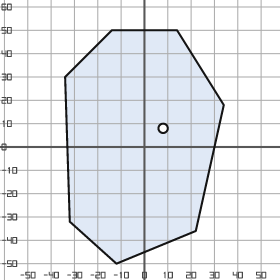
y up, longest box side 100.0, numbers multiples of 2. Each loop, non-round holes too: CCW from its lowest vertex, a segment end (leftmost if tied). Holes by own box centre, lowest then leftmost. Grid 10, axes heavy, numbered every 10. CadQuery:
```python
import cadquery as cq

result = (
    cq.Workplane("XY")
    .moveTo(-12.0, -50.0)
    .lineTo(22.0, -36.0)
    .lineTo(34.0, 18.0)
    .lineTo(14.0, 50.0)
    .lineTo(-14.0, 50.0)
    .lineTo(-34.0, 30.0)
    .lineTo(-32.0, -32.0)
    .close()
    .moveTo(8.0, 8.0)
    .circle(2.0)
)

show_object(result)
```